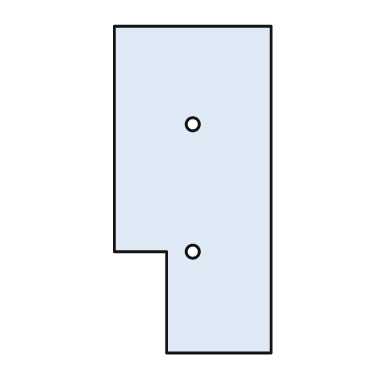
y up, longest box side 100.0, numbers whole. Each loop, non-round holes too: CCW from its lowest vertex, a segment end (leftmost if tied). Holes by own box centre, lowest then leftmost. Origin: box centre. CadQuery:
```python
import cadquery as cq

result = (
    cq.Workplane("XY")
    .moveTo(-8.0, -50.0)
    .lineTo(24.0, -50.0)
    .lineTo(24.0, 50.0)
    .lineTo(-24.0, 50.0)
    .lineTo(-24.0, -19.0)
    .lineTo(-8.0, -19.0)
    .close()
    .moveTo(0.0, -19.0)
    .circle(2.0)
    .moveTo(0.0, 20.0)
    .circle(2.0)
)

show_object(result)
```